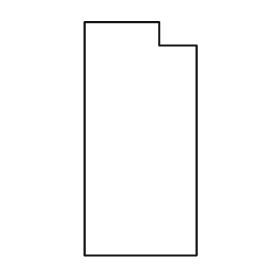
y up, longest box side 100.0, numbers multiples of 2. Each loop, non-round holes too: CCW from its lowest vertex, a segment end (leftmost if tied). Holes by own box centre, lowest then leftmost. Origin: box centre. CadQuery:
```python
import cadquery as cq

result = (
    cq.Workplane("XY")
    .moveTo(-24.0, -50.0)
    .lineTo(24.0, -50.0)
    .lineTo(24.0, 40.0)
    .lineTo(8.0, 40.0)
    .lineTo(8.0, 50.0)
    .lineTo(-24.0, 50.0)
    .close()
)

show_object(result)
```